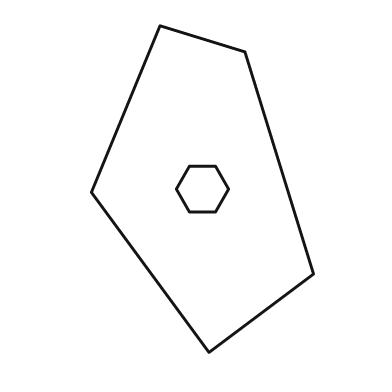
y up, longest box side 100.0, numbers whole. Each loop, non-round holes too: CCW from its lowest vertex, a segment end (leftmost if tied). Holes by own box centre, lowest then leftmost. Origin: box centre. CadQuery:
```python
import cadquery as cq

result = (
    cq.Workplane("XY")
    .moveTo(2.0, -50.0)
    .lineTo(34.0, -26.0)
    .lineTo(13.0, 42.0)
    .lineTo(-13.0, 50.0)
    .lineTo(-34.0, -1.0)
    .close()
    .moveTo(-4.0, -7.0)
    .lineTo(4.0, -7.0)
    .lineTo(8.0, 0.0)
    .lineTo(4.0, 7.0)
    .lineTo(-4.0, 7.0)
    .lineTo(-8.0, 0.0)
    .close()
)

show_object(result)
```